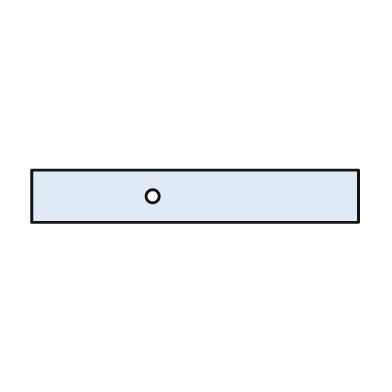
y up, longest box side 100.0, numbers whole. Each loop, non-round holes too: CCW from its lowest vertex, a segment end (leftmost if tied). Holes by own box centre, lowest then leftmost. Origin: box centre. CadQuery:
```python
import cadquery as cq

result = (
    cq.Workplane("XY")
    .moveTo(-50.0, -8.0)
    .lineTo(50.0, -8.0)
    .lineTo(50.0, 8.0)
    .lineTo(-50.0, 8.0)
    .close()
    .moveTo(-13.0, 0.0)
    .circle(2.0)
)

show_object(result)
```